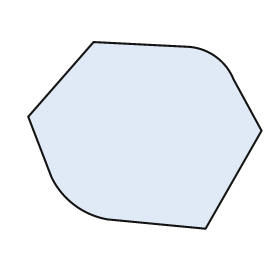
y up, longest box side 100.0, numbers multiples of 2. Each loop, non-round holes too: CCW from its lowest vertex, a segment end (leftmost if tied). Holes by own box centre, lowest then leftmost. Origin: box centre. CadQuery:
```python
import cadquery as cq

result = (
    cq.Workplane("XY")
    .moveTo(26.0, -40.0)
    .lineTo(50.0, 2.0)
    .lineTo(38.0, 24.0)
    .threePointArc((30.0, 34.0), (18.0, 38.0))
    .lineTo(-22.0, 40.0)
    .lineTo(-50.0, 8.0)
    .lineTo(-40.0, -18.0)
    .threePointArc((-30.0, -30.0), (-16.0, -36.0))
    .close()
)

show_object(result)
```